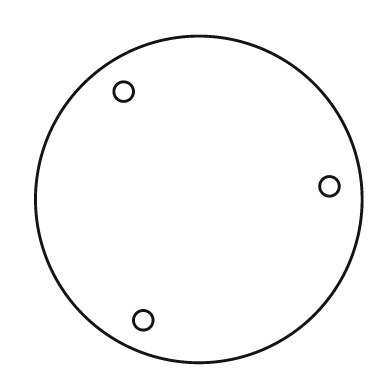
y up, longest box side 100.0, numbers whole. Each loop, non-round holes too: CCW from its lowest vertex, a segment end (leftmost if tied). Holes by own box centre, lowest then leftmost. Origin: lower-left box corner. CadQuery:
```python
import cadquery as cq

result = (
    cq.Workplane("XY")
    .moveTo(50.0, 50.0)
    .circle(50.0)
    .moveTo(33.0, 13.0)
    .circle(3.0)
    .moveTo(90.0, 54.0)
    .circle(3.0)
    .moveTo(27.0, 83.0)
    .circle(3.0)
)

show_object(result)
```